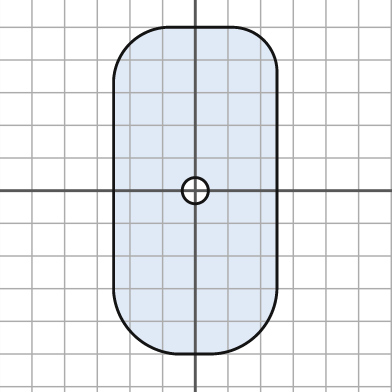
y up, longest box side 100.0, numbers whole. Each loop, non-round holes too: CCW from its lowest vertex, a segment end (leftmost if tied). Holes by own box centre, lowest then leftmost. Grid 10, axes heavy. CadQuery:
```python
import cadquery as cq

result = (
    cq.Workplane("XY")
    .moveTo(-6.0, -50.0)
    .lineTo(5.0, -50.0)
    .threePointArc((19.0, -44.0), (25.0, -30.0))
    .lineTo(25.0, 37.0)
    .threePointArc((21.0, 46.0), (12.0, 50.0))
    .lineTo(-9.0, 50.0)
    .threePointArc((-20.0, 45.0), (-25.0, 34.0))
    .lineTo(-25.0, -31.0)
    .threePointArc((-19.0, -44.0), (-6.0, -50.0))
    .close()
    .moveTo(0.0, 0.0)
    .circle(4.0)
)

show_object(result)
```